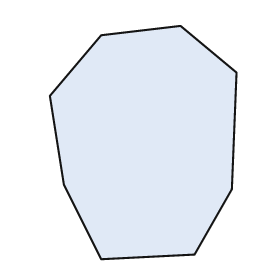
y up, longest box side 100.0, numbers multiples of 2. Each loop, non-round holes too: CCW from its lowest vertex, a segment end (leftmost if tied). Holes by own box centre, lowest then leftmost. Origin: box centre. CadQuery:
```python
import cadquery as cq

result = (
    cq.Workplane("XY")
    .moveTo(-18.0, -50.0)
    .lineTo(22.0, -48.0)
    .lineTo(38.0, -20.0)
    .lineTo(40.0, 30.0)
    .lineTo(16.0, 50.0)
    .lineTo(-18.0, 46.0)
    .lineTo(-40.0, 20.0)
    .lineTo(-34.0, -18.0)
    .close()
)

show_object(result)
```